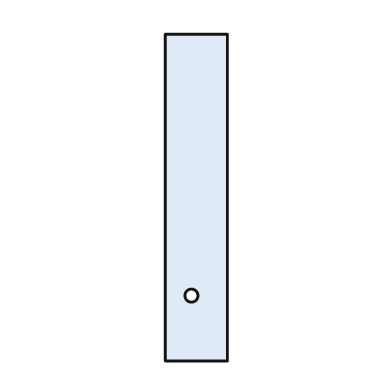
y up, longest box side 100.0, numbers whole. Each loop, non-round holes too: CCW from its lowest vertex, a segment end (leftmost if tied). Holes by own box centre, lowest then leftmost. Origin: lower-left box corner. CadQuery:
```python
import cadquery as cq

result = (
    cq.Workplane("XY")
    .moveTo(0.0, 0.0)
    .lineTo(19.0, 0.0)
    .lineTo(19.0, 100.0)
    .lineTo(0.0, 100.0)
    .close()
    .moveTo(8.0, 20.0)
    .circle(2.0)
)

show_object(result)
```